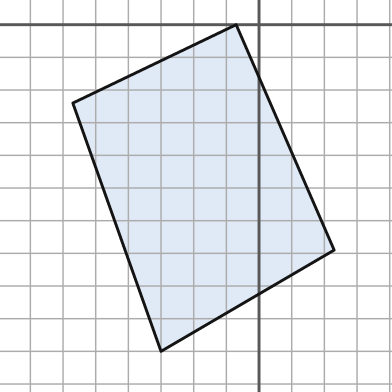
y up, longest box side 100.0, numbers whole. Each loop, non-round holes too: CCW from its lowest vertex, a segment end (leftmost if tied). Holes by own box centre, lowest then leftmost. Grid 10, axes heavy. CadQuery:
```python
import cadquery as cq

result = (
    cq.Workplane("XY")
    .moveTo(-30.0, -100.0)
    .lineTo(23.0, -69.0)
    .lineTo(-7.0, 0.0)
    .lineTo(-57.0, -24.0)
    .close()
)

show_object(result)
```